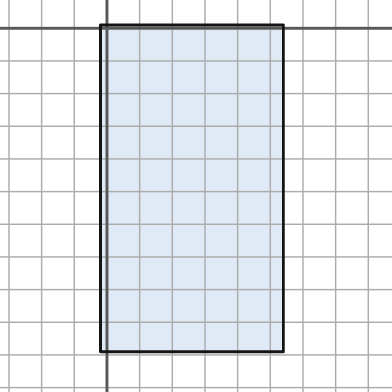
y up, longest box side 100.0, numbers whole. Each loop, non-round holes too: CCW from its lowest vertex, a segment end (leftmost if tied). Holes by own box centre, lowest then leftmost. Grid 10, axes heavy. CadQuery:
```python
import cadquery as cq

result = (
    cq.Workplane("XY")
    .moveTo(-2.0, -99.0)
    .lineTo(54.0, -99.0)
    .lineTo(54.0, 1.0)
    .lineTo(-2.0, 1.0)
    .close()
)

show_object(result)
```